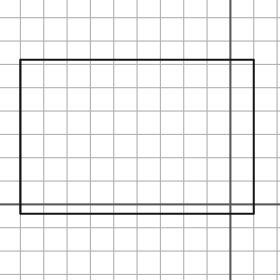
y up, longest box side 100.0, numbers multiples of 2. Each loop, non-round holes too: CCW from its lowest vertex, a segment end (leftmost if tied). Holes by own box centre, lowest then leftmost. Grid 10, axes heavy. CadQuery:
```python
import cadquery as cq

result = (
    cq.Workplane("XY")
    .moveTo(-90.0, -4.0)
    .lineTo(10.0, -4.0)
    .lineTo(10.0, 62.0)
    .lineTo(-90.0, 62.0)
    .close()
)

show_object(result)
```